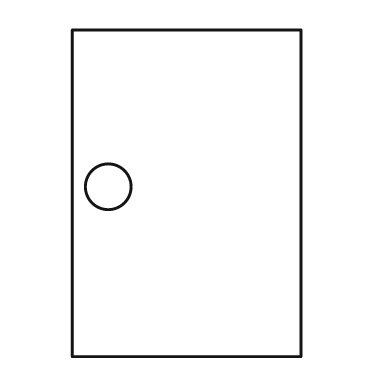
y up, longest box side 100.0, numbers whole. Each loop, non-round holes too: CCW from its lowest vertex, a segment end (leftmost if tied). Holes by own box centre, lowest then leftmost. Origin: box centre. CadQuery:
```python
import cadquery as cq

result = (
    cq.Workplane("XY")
    .moveTo(-35.0, -50.0)
    .lineTo(35.0, -50.0)
    .lineTo(35.0, 50.0)
    .lineTo(-35.0, 50.0)
    .close()
    .moveTo(-24.0, 2.0)
    .circle(7.0)
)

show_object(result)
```